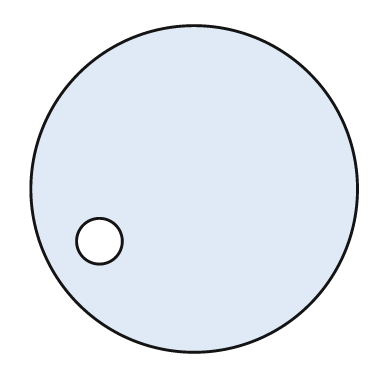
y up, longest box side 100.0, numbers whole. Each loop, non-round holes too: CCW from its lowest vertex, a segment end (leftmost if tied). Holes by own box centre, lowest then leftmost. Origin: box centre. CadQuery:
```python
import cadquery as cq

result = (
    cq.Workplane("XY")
    .moveTo(0.0, 0.0)
    .circle(50.0)
    .moveTo(-29.0, -16.0)
    .circle(7.0)
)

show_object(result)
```